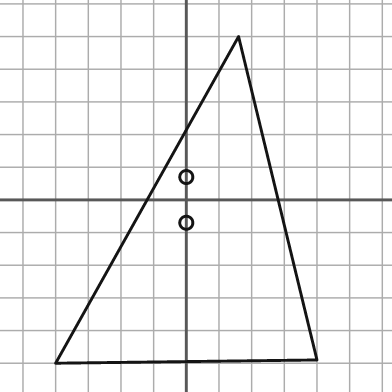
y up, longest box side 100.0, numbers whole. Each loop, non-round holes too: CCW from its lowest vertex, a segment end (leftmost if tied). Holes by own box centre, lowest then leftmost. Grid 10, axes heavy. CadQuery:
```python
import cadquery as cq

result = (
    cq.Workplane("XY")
    .moveTo(-40.0, -50.0)
    .lineTo(40.0, -49.0)
    .lineTo(16.0, 50.0)
    .close()
    .moveTo(0.0, -7.0)
    .circle(2.0)
    .moveTo(0.0, 7.0)
    .circle(2.0)
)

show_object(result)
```